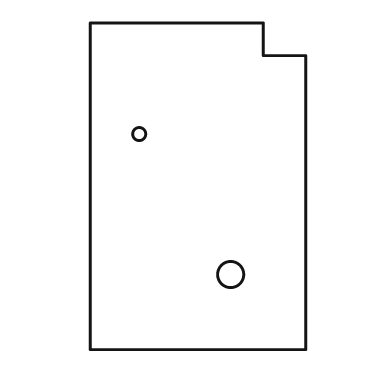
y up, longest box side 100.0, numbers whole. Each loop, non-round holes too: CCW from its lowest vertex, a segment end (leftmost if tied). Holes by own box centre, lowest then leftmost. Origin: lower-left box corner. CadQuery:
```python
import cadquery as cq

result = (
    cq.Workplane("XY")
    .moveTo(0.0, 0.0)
    .lineTo(66.0, 0.0)
    .lineTo(66.0, 90.0)
    .lineTo(53.0, 90.0)
    .lineTo(53.0, 100.0)
    .lineTo(0.0, 100.0)
    .close()
    .moveTo(43.0, 23.0)
    .circle(4.0)
    .moveTo(15.0, 66.0)
    .circle(2.0)
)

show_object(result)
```